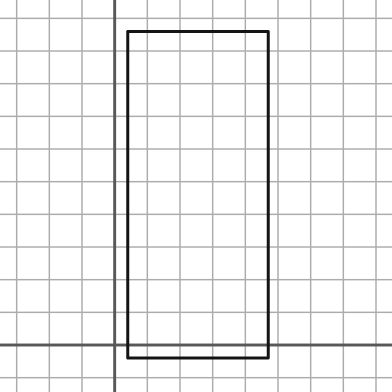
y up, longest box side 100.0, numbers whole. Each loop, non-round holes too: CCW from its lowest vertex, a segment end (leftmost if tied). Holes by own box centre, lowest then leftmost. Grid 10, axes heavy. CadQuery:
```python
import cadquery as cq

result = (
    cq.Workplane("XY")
    .moveTo(4.0, -4.0)
    .lineTo(47.0, -4.0)
    .lineTo(47.0, 96.0)
    .lineTo(4.0, 96.0)
    .close()
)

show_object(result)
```